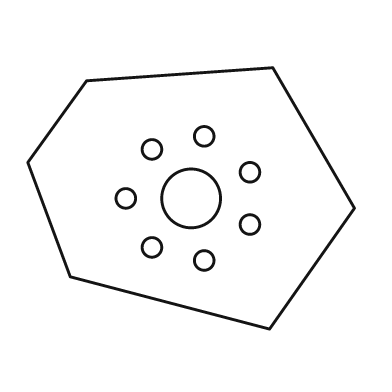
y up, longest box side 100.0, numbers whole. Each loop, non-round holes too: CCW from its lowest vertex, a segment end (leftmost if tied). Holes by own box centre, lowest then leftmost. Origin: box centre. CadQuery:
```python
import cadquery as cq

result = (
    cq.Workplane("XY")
    .moveTo(24.0, -40.0)
    .lineTo(50.0, -3.0)
    .lineTo(25.0, 40.0)
    .lineTo(-32.0, 36.0)
    .lineTo(-50.0, 11.0)
    .lineTo(-37.0, -24.0)
    .close()
    .moveTo(4.0, -19.0)
    .circle(3.0)
    .moveTo(-12.0, -15.0)
    .circle(3.0)
    .moveTo(18.0, -8.0)
    .circle(3.0)
    .moveTo(-20.0, 0.0)
    .circle(3.0)
    .moveTo(0.0, 0.0)
    .circle(9.0)
    .moveTo(18.0, 8.0)
    .circle(3.0)
    .moveTo(-12.0, 15.0)
    .circle(3.0)
    .moveTo(4.0, 19.0)
    .circle(3.0)
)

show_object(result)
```